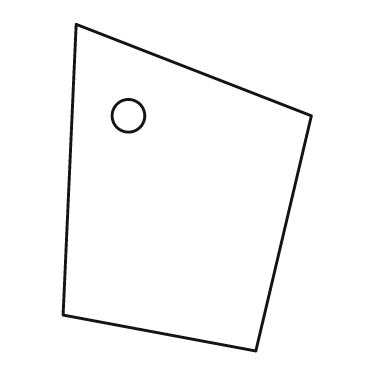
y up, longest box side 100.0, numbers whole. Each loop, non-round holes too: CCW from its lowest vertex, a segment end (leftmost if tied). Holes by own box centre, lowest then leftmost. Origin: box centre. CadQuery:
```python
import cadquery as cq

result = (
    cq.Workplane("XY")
    .moveTo(21.0, -50.0)
    .lineTo(38.0, 22.0)
    .lineTo(-34.0, 50.0)
    .lineTo(-38.0, -39.0)
    .close()
    .moveTo(-18.0, 22.0)
    .circle(5.0)
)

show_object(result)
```